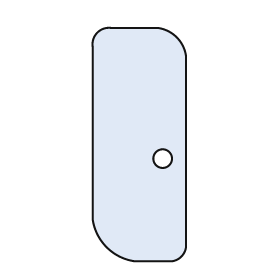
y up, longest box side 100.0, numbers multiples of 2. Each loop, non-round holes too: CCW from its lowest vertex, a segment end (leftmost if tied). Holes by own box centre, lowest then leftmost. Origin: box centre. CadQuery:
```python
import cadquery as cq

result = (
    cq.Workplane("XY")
    .moveTo(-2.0, -50.0)
    .lineTo(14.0, -50.0)
    .threePointArc((18.0, -48.0), (20.0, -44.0))
    .lineTo(20.0, 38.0)
    .threePointArc((16.0, 46.0), (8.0, 50.0))
    .lineTo(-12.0, 50.0)
    .threePointArc((-18.0, 48.0), (-20.0, 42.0))
    .lineTo(-20.0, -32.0)
    .threePointArc((-14.0, -44.0), (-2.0, -50.0))
    .close()
    .moveTo(10.0, -6.0)
    .circle(4.0)
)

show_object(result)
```